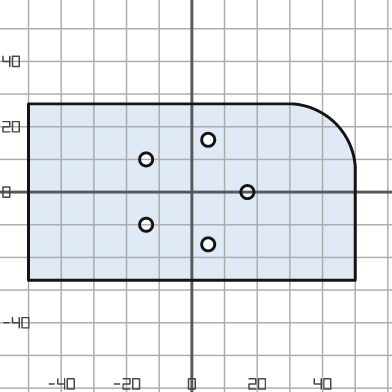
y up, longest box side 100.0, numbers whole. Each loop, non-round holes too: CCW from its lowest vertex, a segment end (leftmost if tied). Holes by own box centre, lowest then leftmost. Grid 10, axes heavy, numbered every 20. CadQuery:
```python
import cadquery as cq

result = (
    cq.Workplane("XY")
    .moveTo(-50.0, -27.0)
    .lineTo(50.0, -27.0)
    .lineTo(50.0, 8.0)
    .threePointArc((44.0, 21.0), (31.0, 27.0))
    .lineTo(-50.0, 27.0)
    .close()
    .moveTo(5.0, -16.0)
    .circle(2.0)
    .moveTo(-14.0, -10.0)
    .circle(2.0)
    .moveTo(17.0, 0.0)
    .circle(2.0)
    .moveTo(-14.0, 10.0)
    .circle(2.0)
    .moveTo(5.0, 16.0)
    .circle(2.0)
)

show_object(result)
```